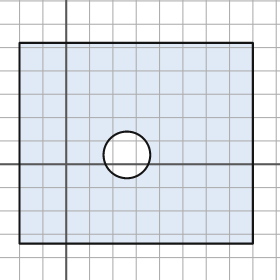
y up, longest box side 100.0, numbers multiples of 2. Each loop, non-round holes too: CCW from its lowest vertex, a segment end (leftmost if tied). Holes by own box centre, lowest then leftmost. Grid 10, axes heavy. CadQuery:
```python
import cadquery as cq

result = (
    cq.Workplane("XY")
    .moveTo(-20.0, -34.0)
    .lineTo(80.0, -34.0)
    .lineTo(80.0, 52.0)
    .lineTo(-20.0, 52.0)
    .close()
    .moveTo(26.0, 4.0)
    .circle(10.0)
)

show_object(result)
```